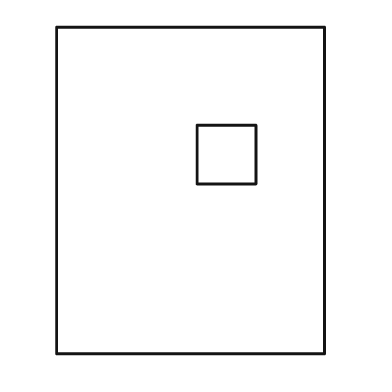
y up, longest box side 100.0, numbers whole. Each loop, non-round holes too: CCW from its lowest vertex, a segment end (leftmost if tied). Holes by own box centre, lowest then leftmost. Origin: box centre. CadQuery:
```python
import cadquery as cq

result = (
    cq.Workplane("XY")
    .moveTo(-41.0, -50.0)
    .lineTo(41.0, -50.0)
    .lineTo(41.0, 50.0)
    .lineTo(-41.0, 50.0)
    .close()
    .moveTo(2.0, 2.0)
    .lineTo(20.0, 2.0)
    .lineTo(20.0, 20.0)
    .lineTo(2.0, 20.0)
    .close()
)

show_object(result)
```